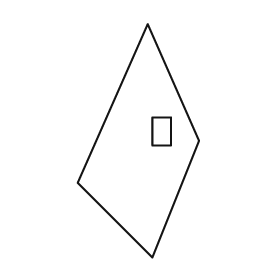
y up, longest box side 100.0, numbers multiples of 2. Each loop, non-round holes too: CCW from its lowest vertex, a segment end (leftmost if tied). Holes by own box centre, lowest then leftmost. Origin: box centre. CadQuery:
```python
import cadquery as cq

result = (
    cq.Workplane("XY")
    .moveTo(6.0, -50.0)
    .lineTo(26.0, 0.0)
    .lineTo(4.0, 50.0)
    .lineTo(-26.0, -18.0)
    .close()
    .moveTo(6.0, -2.0)
    .lineTo(14.0, -2.0)
    .lineTo(14.0, 10.0)
    .lineTo(6.0, 10.0)
    .close()
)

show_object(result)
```